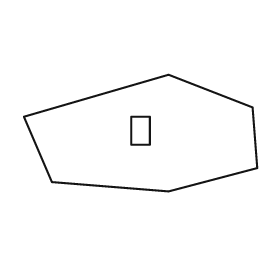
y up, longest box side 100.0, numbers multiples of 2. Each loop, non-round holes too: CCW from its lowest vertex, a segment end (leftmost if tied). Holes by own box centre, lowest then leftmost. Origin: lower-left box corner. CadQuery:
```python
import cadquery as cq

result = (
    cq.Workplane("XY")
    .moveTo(62.0, 0.0)
    .lineTo(100.0, 10.0)
    .lineTo(98.0, 36.0)
    .lineTo(62.0, 50.0)
    .lineTo(0.0, 32.0)
    .lineTo(12.0, 4.0)
    .close()
    .moveTo(46.0, 20.0)
    .lineTo(54.0, 20.0)
    .lineTo(54.0, 32.0)
    .lineTo(46.0, 32.0)
    .close()
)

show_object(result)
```